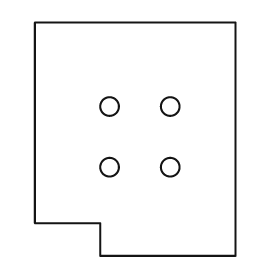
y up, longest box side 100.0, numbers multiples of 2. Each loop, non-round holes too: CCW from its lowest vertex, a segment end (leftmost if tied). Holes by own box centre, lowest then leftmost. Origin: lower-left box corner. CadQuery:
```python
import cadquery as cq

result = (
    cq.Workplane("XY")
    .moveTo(28.0, 0.0)
    .lineTo(86.0, 0.0)
    .lineTo(86.0, 100.0)
    .lineTo(0.0, 100.0)
    .lineTo(0.0, 14.0)
    .lineTo(28.0, 14.0)
    .close()
    .moveTo(32.0, 38.0)
    .circle(4.0)
    .moveTo(58.0, 38.0)
    .circle(4.0)
    .moveTo(32.0, 64.0)
    .circle(4.0)
    .moveTo(58.0, 64.0)
    .circle(4.0)
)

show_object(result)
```